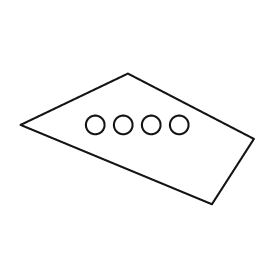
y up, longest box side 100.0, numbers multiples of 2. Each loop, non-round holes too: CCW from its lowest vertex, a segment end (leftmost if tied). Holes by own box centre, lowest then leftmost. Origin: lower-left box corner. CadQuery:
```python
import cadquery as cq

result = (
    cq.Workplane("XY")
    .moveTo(82.0, 0.0)
    .lineTo(100.0, 28.0)
    .lineTo(46.0, 56.0)
    .lineTo(0.0, 34.0)
    .close()
    .moveTo(32.0, 34.0)
    .circle(4.0)
    .moveTo(44.0, 34.0)
    .circle(4.0)
    .moveTo(56.0, 34.0)
    .circle(4.0)
    .moveTo(68.0, 34.0)
    .circle(4.0)
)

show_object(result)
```